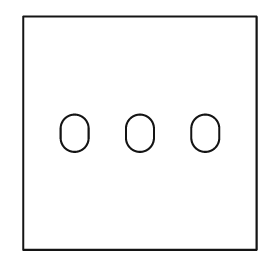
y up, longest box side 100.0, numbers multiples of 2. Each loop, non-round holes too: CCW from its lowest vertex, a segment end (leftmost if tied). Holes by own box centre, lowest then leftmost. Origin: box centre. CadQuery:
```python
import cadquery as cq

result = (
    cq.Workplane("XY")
    .moveTo(-50.0, -50.0)
    .lineTo(50.0, -50.0)
    .lineTo(50.0, 50.0)
    .lineTo(-50.0, 50.0)
    .close()
    .moveTo(-34.0, -2.0)
    .threePointArc((-28.0, -8.0), (-22.0, -2.0))
    .lineTo(-22.0, 2.0)
    .threePointArc((-28.0, 8.0), (-34.0, 2.0))
    .close()
    .moveTo(-6.0, -2.0)
    .threePointArc((0.0, -8.0), (6.0, -2.0))
    .lineTo(6.0, 2.0)
    .threePointArc((0.0, 8.0), (-6.0, 2.0))
    .close()
    .moveTo(22.0, -2.0)
    .threePointArc((28.0, -8.0), (34.0, -2.0))
    .lineTo(34.0, 2.0)
    .threePointArc((28.0, 8.0), (22.0, 2.0))
    .close()
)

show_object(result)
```